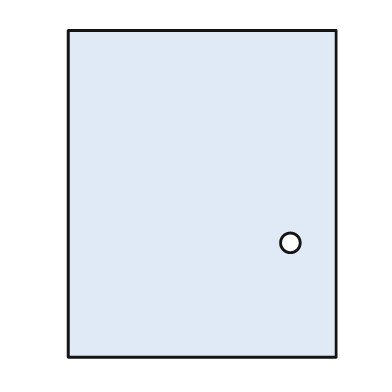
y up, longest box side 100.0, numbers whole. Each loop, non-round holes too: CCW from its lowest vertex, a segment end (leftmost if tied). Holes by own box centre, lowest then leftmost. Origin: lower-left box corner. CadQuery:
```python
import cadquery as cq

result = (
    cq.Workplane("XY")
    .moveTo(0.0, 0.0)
    .lineTo(82.0, 0.0)
    .lineTo(82.0, 100.0)
    .lineTo(0.0, 100.0)
    .close()
    .moveTo(68.0, 35.0)
    .circle(3.0)
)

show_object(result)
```